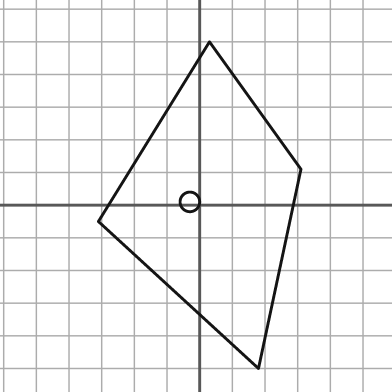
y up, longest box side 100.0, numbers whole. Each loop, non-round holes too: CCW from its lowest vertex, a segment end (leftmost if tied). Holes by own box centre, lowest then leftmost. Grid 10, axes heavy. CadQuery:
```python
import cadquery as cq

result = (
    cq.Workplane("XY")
    .moveTo(18.0, -50.0)
    .lineTo(31.0, 11.0)
    .lineTo(3.0, 50.0)
    .lineTo(-31.0, -5.0)
    .close()
    .moveTo(-3.0, 1.0)
    .circle(3.0)
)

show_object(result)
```